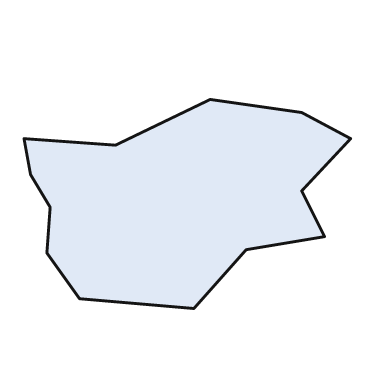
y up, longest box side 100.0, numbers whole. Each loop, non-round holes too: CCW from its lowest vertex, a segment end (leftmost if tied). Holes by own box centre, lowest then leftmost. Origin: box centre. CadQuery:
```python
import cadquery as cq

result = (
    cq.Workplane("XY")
    .moveTo(2.0, -32.0)
    .lineTo(18.0, -14.0)
    .lineTo(42.0, -10.0)
    .lineTo(35.0, 4.0)
    .lineTo(50.0, 20.0)
    .lineTo(35.0, 28.0)
    .lineTo(7.0, 32.0)
    .lineTo(-22.0, 18.0)
    .lineTo(-50.0, 20.0)
    .lineTo(-48.0, 9.0)
    .lineTo(-42.0, -1.0)
    .lineTo(-43.0, -15.0)
    .lineTo(-33.0, -29.0)
    .close()
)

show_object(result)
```